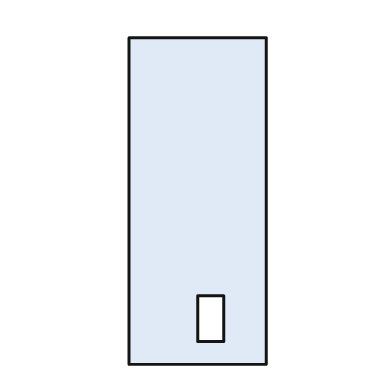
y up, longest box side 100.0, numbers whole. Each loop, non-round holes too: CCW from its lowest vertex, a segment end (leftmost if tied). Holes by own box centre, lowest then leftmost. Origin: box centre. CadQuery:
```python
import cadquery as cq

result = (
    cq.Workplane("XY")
    .moveTo(-21.0, -50.0)
    .lineTo(21.0, -50.0)
    .lineTo(21.0, 50.0)
    .lineTo(-21.0, 50.0)
    .close()
    .moveTo(0.0, -43.0)
    .lineTo(8.0, -43.0)
    .lineTo(8.0, -29.0)
    .lineTo(0.0, -29.0)
    .close()
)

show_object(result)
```